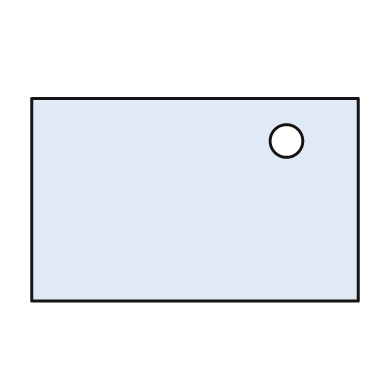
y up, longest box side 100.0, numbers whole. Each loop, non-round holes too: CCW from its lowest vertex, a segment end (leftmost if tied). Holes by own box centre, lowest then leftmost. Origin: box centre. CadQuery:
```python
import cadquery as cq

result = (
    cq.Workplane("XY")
    .moveTo(-50.0, -31.0)
    .lineTo(50.0, -31.0)
    .lineTo(50.0, 31.0)
    .lineTo(-50.0, 31.0)
    .close()
    .moveTo(28.0, 18.0)
    .circle(5.0)
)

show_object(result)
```